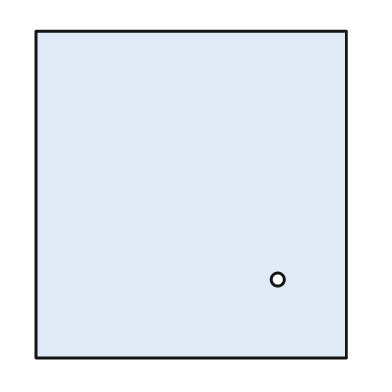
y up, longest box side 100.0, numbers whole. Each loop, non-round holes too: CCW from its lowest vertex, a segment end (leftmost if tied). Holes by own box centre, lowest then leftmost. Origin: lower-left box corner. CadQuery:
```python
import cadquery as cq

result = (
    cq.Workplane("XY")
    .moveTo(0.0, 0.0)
    .lineTo(95.0, 0.0)
    .lineTo(95.0, 100.0)
    .lineTo(0.0, 100.0)
    .close()
    .moveTo(74.0, 24.0)
    .circle(2.0)
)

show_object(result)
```